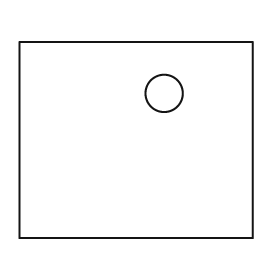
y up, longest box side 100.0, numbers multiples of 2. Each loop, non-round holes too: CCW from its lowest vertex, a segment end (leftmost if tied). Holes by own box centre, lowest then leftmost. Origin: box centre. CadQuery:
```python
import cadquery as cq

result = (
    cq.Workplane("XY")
    .moveTo(-50.0, -42.0)
    .lineTo(50.0, -42.0)
    .lineTo(50.0, 42.0)
    .lineTo(-50.0, 42.0)
    .close()
    .moveTo(12.0, 20.0)
    .circle(8.0)
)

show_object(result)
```